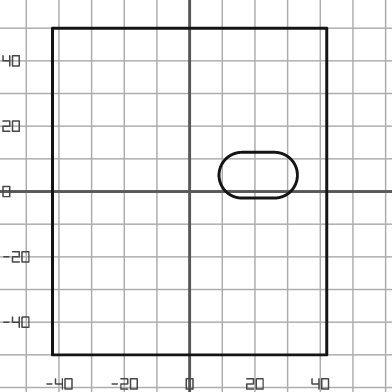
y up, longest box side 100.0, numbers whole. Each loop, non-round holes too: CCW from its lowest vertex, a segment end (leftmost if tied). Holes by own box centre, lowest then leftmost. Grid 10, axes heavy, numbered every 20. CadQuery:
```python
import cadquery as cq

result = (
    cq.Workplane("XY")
    .moveTo(-42.0, -50.0)
    .lineTo(42.0, -50.0)
    .lineTo(42.0, 50.0)
    .lineTo(-42.0, 50.0)
    .close()
    .moveTo(16.0, -2.0)
    .lineTo(26.0, -2.0)
    .threePointArc((33.0, 5.0), (26.0, 12.0))
    .lineTo(16.0, 12.0)
    .threePointArc((9.0, 5.0), (16.0, -2.0))
    .close()
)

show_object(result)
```